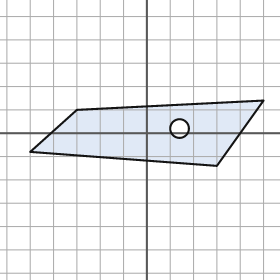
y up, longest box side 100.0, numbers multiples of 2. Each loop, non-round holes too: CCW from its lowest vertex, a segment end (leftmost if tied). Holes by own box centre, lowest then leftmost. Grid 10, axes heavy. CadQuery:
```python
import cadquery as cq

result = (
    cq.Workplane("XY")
    .moveTo(30.0, -14.0)
    .lineTo(50.0, 14.0)
    .lineTo(-30.0, 10.0)
    .lineTo(-50.0, -8.0)
    .close()
    .moveTo(14.0, 2.0)
    .circle(4.0)
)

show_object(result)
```